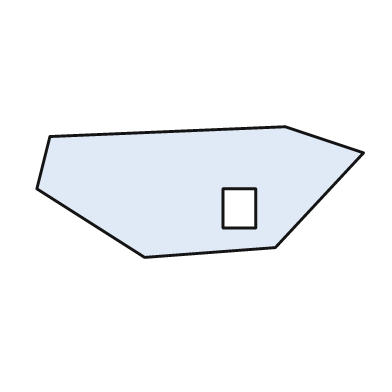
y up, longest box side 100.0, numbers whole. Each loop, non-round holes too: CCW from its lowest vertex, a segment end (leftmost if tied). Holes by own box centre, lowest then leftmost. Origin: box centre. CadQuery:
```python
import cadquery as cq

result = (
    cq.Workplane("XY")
    .moveTo(-17.0, -20.0)
    .lineTo(23.0, -17.0)
    .lineTo(50.0, 12.0)
    .lineTo(26.0, 20.0)
    .lineTo(-46.0, 17.0)
    .lineTo(-50.0, 1.0)
    .close()
    .moveTo(7.0, -11.0)
    .lineTo(17.0, -11.0)
    .lineTo(17.0, 1.0)
    .lineTo(7.0, 1.0)
    .close()
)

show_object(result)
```